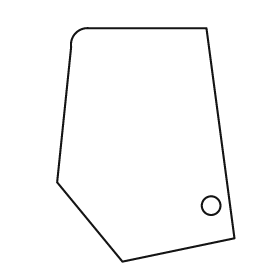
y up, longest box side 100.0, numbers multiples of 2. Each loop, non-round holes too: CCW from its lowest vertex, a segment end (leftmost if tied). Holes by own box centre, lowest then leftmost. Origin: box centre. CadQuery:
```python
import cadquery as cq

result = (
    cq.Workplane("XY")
    .moveTo(-10.0, -50.0)
    .lineTo(38.0, -40.0)
    .lineTo(26.0, 50.0)
    .lineTo(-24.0, 50.0)
    .threePointArc((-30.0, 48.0), (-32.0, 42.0))
    .lineTo(-38.0, -16.0)
    .close()
    .moveTo(28.0, -26.0)
    .circle(4.0)
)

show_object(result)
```